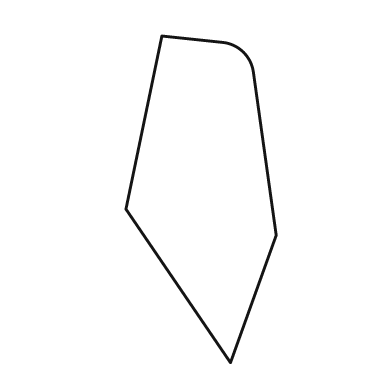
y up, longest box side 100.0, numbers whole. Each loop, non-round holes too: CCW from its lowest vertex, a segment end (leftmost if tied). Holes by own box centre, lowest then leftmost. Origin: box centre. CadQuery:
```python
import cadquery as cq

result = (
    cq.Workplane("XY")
    .moveTo(9.0, -50.0)
    .lineTo(23.0, -11.0)
    .lineTo(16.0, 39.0)
    .threePointArc((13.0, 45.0), (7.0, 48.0))
    .lineTo(-12.0, 50.0)
    .lineTo(-23.0, -3.0)
    .close()
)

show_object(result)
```